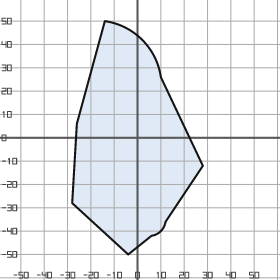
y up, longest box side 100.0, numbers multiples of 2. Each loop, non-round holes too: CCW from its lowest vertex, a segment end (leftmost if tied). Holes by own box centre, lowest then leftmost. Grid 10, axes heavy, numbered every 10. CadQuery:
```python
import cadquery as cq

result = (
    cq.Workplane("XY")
    .moveTo(-4.0, -50.0)
    .lineTo(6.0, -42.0)
    .threePointArc((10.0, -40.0), (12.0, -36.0))
    .lineTo(28.0, -12.0)
    .lineTo(10.0, 26.0)
    .threePointArc((2.0, 42.0), (-14.0, 50.0))
    .lineTo(-26.0, 6.0)
    .lineTo(-28.0, -28.0)
    .close()
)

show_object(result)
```